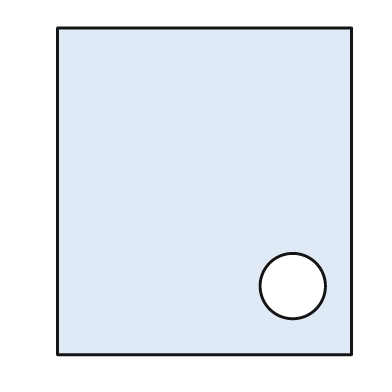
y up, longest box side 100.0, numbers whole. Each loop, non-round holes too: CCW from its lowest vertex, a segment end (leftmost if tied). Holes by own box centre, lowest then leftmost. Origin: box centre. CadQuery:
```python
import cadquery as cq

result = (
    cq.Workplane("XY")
    .moveTo(-45.0, -50.0)
    .lineTo(45.0, -50.0)
    .lineTo(45.0, 50.0)
    .lineTo(-45.0, 50.0)
    .close()
    .moveTo(27.0, -29.0)
    .circle(10.0)
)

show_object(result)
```